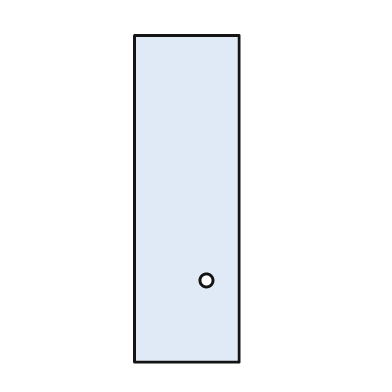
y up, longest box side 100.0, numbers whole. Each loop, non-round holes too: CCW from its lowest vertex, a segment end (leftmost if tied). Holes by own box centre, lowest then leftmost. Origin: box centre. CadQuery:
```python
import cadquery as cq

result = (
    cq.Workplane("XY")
    .moveTo(-16.0, -50.0)
    .lineTo(16.0, -50.0)
    .lineTo(16.0, 50.0)
    .lineTo(-16.0, 50.0)
    .close()
    .moveTo(6.0, -25.0)
    .circle(2.0)
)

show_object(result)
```